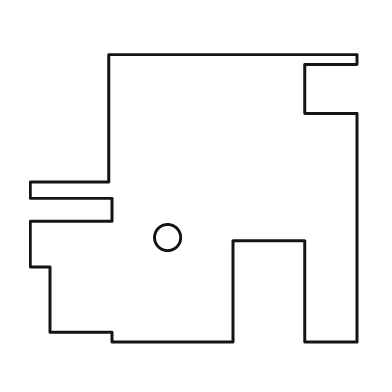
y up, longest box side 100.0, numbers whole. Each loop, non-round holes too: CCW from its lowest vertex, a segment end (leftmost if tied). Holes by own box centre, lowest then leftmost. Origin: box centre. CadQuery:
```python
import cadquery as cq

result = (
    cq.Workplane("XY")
    .moveTo(-25.0, -44.0)
    .lineTo(12.0, -44.0)
    .lineTo(12.0, -13.0)
    .lineTo(34.0, -13.0)
    .lineTo(34.0, -44.0)
    .lineTo(50.0, -44.0)
    .lineTo(50.0, 26.0)
    .lineTo(34.0, 26.0)
    .lineTo(34.0, 41.0)
    .lineTo(50.0, 41.0)
    .lineTo(50.0, 44.0)
    .lineTo(-26.0, 44.0)
    .lineTo(-26.0, 5.0)
    .lineTo(-50.0, 5.0)
    .lineTo(-50.0, 0.0)
    .lineTo(-25.0, 0.0)
    .lineTo(-25.0, -7.0)
    .lineTo(-50.0, -7.0)
    .lineTo(-50.0, -21.0)
    .lineTo(-44.0, -21.0)
    .lineTo(-44.0, -41.0)
    .lineTo(-25.0, -41.0)
    .close()
    .moveTo(-8.0, -12.0)
    .circle(4.0)
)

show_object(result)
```